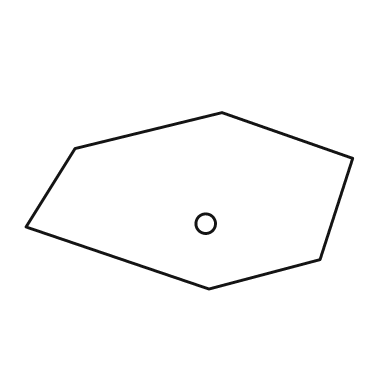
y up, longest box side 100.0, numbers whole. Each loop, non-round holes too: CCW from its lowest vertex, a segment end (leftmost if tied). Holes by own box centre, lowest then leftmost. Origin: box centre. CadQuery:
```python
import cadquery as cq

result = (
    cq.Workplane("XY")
    .moveTo(6.0, -27.0)
    .lineTo(40.0, -18.0)
    .lineTo(50.0, 13.0)
    .lineTo(10.0, 27.0)
    .lineTo(-35.0, 16.0)
    .lineTo(-50.0, -8.0)
    .close()
    .moveTo(5.0, -7.0)
    .circle(3.0)
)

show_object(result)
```